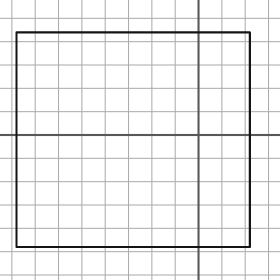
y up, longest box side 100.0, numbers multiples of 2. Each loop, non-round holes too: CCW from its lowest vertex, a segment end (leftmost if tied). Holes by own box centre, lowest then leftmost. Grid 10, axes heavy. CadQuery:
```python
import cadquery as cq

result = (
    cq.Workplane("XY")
    .moveTo(-78.0, -48.0)
    .lineTo(22.0, -48.0)
    .lineTo(22.0, 44.0)
    .lineTo(-78.0, 44.0)
    .close()
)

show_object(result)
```